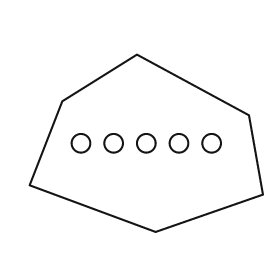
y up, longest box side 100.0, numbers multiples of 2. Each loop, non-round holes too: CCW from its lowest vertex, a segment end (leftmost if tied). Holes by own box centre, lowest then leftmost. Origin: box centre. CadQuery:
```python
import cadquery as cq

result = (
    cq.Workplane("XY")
    .moveTo(4.0, -38.0)
    .lineTo(50.0, -22.0)
    .lineTo(44.0, 12.0)
    .lineTo(-4.0, 38.0)
    .lineTo(-36.0, 18.0)
    .lineTo(-50.0, -18.0)
    .close()
    .moveTo(-28.0, 0.0)
    .circle(4.0)
    .moveTo(-14.0, 0.0)
    .circle(4.0)
    .moveTo(0.0, 0.0)
    .circle(4.0)
    .moveTo(14.0, 0.0)
    .circle(4.0)
    .moveTo(28.0, 0.0)
    .circle(4.0)
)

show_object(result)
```